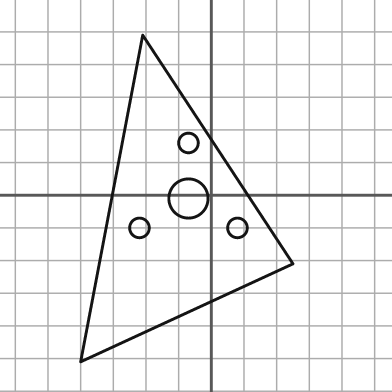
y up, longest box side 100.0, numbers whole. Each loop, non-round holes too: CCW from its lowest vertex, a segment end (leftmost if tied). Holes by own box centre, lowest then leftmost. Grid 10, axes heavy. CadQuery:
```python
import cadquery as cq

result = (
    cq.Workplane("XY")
    .moveTo(-40.0, -51.0)
    .lineTo(25.0, -21.0)
    .lineTo(-21.0, 49.0)
    .close()
    .moveTo(-22.0, -10.0)
    .circle(3.0)
    .moveTo(8.0, -10.0)
    .circle(3.0)
    .moveTo(-7.0, -1.0)
    .circle(6.0)
    .moveTo(-7.0, 16.0)
    .circle(3.0)
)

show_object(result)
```